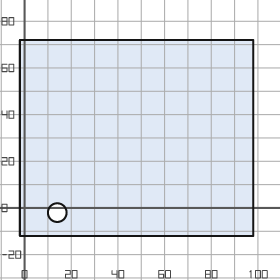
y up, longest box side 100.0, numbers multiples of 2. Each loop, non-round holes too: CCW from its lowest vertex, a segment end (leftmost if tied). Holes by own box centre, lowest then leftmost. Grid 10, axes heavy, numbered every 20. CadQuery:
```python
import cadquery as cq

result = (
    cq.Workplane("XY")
    .moveTo(-2.0, -12.0)
    .lineTo(98.0, -12.0)
    .lineTo(98.0, 72.0)
    .lineTo(-2.0, 72.0)
    .close()
    .moveTo(14.0, -2.0)
    .circle(4.0)
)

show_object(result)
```